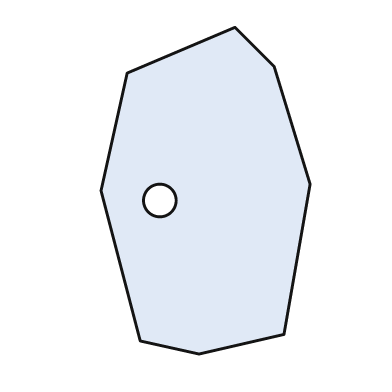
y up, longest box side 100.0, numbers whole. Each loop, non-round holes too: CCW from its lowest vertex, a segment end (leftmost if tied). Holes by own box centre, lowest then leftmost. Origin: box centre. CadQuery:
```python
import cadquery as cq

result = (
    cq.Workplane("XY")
    .moveTo(-2.0, -50.0)
    .lineTo(24.0, -44.0)
    .lineTo(32.0, 2.0)
    .lineTo(21.0, 38.0)
    .lineTo(9.0, 50.0)
    .lineTo(-24.0, 36.0)
    .lineTo(-32.0, 0.0)
    .lineTo(-20.0, -46.0)
    .close()
    .moveTo(-14.0, -3.0)
    .circle(5.0)
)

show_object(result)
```